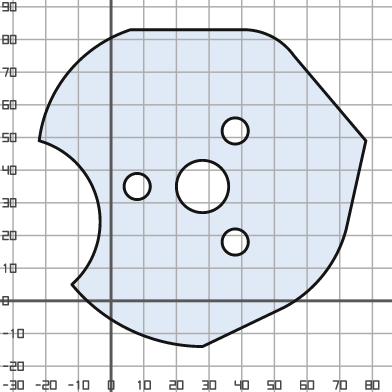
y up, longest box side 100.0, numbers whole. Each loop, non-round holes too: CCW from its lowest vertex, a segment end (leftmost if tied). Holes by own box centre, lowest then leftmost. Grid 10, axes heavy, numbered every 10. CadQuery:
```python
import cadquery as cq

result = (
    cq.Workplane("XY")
    .moveTo(28.0, -14.0)
    .lineTo(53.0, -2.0)
    .threePointArc((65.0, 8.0), (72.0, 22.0))
    .lineTo(78.0, 49.0)
    .lineTo(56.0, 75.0)
    .threePointArc((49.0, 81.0), (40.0, 83.0))
    .lineTo(6.0, 83.0)
    .threePointArc((-13.0, 70.0), (-22.0, 49.0))
    .threePointArc((-4.0, 30.0), (-12.0, 5.0))
    .threePointArc((6.0, -9.0), (28.0, -14.0))
    .close()
    .moveTo(38.0, 18.0)
    .circle(4.0)
    .moveTo(8.0, 35.0)
    .circle(4.0)
    .moveTo(28.0, 35.0)
    .circle(8.0)
    .moveTo(38.0, 52.0)
    .circle(4.0)
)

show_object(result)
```